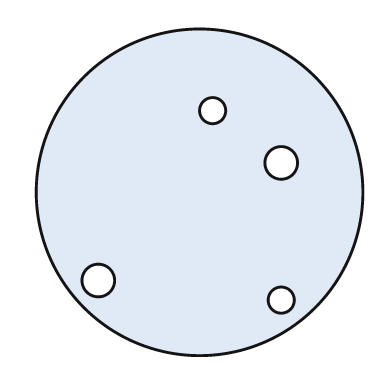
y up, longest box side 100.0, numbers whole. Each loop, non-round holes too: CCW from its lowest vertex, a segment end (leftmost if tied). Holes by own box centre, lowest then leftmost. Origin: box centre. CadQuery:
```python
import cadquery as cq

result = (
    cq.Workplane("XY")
    .moveTo(0.0, 0.0)
    .circle(50.0)
    .moveTo(25.0, -33.0)
    .circle(4.0)
    .moveTo(-31.0, -27.0)
    .circle(5.0)
    .moveTo(25.0, 9.0)
    .circle(5.0)
    .moveTo(4.0, 25.0)
    .circle(4.0)
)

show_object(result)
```